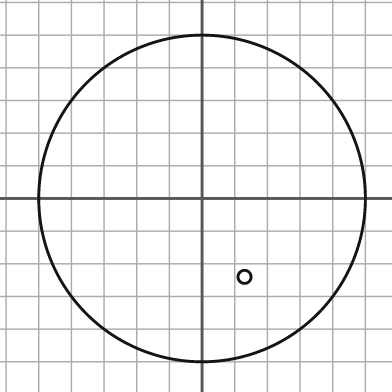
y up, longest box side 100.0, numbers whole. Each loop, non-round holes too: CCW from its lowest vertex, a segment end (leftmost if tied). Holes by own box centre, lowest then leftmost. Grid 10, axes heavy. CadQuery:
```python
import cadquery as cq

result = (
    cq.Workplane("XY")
    .moveTo(0.0, 0.0)
    .circle(50.0)
    .moveTo(13.0, -24.0)
    .circle(2.0)
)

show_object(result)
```